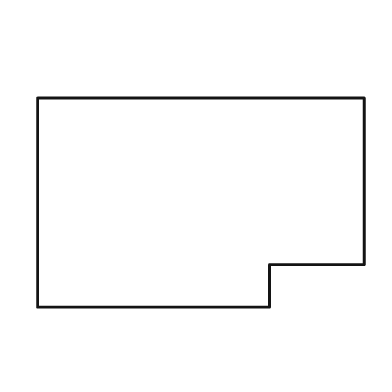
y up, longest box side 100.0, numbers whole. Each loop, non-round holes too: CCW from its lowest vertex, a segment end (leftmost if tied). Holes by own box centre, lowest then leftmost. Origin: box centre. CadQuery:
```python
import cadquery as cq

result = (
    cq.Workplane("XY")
    .moveTo(-50.0, -32.0)
    .lineTo(21.0, -32.0)
    .lineTo(21.0, -19.0)
    .lineTo(50.0, -19.0)
    .lineTo(50.0, 32.0)
    .lineTo(-50.0, 32.0)
    .close()
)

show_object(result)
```